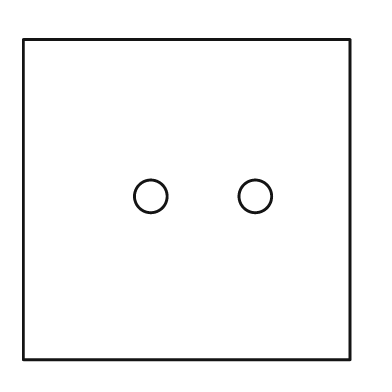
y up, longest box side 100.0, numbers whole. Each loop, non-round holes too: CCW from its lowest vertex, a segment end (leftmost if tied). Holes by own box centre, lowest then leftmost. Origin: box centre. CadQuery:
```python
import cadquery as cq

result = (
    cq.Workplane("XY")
    .moveTo(-50.0, -49.0)
    .lineTo(50.0, -49.0)
    .lineTo(50.0, 49.0)
    .lineTo(-50.0, 49.0)
    .close()
    .moveTo(-11.0, 1.0)
    .circle(5.0)
    .moveTo(21.0, 1.0)
    .circle(5.0)
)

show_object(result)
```